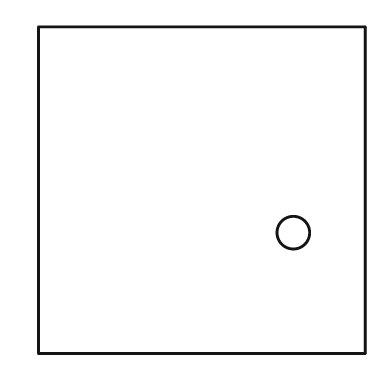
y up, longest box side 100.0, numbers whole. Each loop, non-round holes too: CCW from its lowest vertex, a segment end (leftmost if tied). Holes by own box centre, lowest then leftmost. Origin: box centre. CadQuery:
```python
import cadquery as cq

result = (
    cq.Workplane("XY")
    .moveTo(-50.0, -50.0)
    .lineTo(50.0, -50.0)
    .lineTo(50.0, 50.0)
    .lineTo(-50.0, 50.0)
    .close()
    .moveTo(28.0, -13.0)
    .circle(5.0)
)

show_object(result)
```